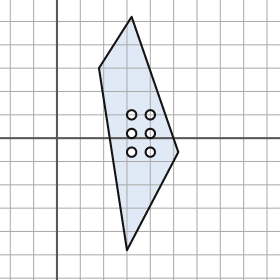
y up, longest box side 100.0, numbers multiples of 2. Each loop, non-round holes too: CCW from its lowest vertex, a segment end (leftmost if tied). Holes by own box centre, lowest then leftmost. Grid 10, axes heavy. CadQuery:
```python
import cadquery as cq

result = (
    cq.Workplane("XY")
    .moveTo(30.0, -48.0)
    .lineTo(52.0, -6.0)
    .lineTo(32.0, 52.0)
    .lineTo(18.0, 30.0)
    .close()
    .moveTo(32.0, -6.0)
    .circle(2.0)
    .moveTo(40.0, -6.0)
    .circle(2.0)
    .moveTo(32.0, 2.0)
    .circle(2.0)
    .moveTo(40.0, 2.0)
    .circle(2.0)
    .moveTo(32.0, 10.0)
    .circle(2.0)
    .moveTo(40.0, 10.0)
    .circle(2.0)
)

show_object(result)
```